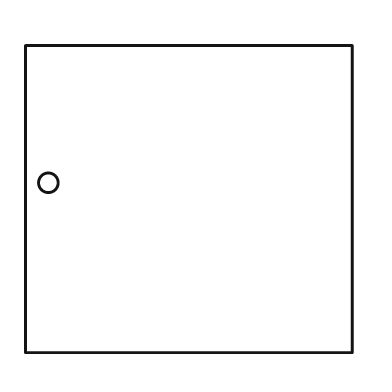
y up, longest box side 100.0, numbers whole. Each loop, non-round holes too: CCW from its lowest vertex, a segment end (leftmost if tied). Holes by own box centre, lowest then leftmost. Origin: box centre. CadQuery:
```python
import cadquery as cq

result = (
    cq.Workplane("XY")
    .moveTo(-50.0, -47.0)
    .lineTo(50.0, -47.0)
    .lineTo(50.0, 47.0)
    .lineTo(-50.0, 47.0)
    .close()
    .moveTo(-43.0, 5.0)
    .circle(3.0)
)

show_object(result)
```